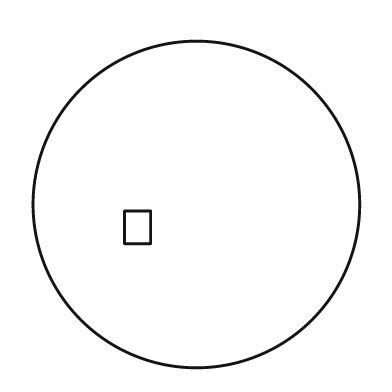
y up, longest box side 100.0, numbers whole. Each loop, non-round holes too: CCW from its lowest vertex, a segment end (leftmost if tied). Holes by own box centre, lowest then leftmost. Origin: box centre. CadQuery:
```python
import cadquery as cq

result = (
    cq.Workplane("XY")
    .moveTo(0.0, 0.0)
    .circle(50.0)
    .moveTo(-22.0, -12.0)
    .lineTo(-14.0, -12.0)
    .lineTo(-14.0, -2.0)
    .lineTo(-22.0, -2.0)
    .close()
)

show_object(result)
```